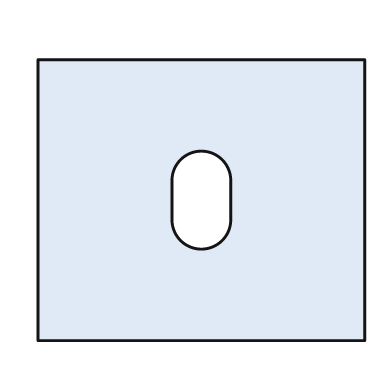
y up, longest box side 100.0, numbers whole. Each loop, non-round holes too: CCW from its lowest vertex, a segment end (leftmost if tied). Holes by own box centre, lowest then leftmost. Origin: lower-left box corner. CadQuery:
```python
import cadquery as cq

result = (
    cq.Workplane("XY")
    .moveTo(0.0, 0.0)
    .lineTo(100.0, 0.0)
    .lineTo(100.0, 86.0)
    .lineTo(0.0, 86.0)
    .close()
    .moveTo(41.0, 37.0)
    .threePointArc((50.0, 28.0), (59.0, 37.0))
    .lineTo(59.0, 49.0)
    .threePointArc((50.0, 58.0), (41.0, 49.0))
    .close()
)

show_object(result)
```